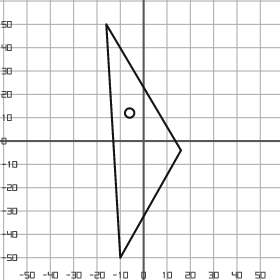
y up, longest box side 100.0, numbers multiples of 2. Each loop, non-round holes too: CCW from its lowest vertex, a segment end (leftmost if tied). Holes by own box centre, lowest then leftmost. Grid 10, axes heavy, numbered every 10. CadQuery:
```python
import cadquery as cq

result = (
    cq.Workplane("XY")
    .moveTo(-10.0, -50.0)
    .lineTo(16.0, -4.0)
    .lineTo(-16.0, 50.0)
    .close()
    .moveTo(-6.0, 12.0)
    .circle(2.0)
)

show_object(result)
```